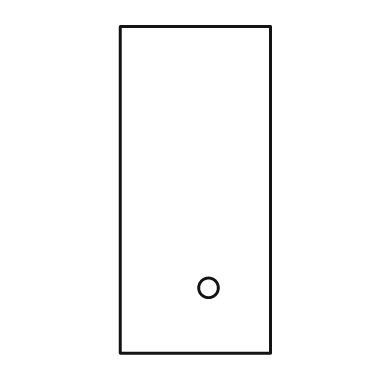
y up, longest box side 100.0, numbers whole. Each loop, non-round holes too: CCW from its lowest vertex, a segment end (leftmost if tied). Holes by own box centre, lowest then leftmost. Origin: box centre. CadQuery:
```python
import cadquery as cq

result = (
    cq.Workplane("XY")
    .moveTo(-23.0, -50.0)
    .lineTo(23.0, -50.0)
    .lineTo(23.0, 50.0)
    .lineTo(-23.0, 50.0)
    .close()
    .moveTo(4.0, -30.0)
    .circle(3.0)
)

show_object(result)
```